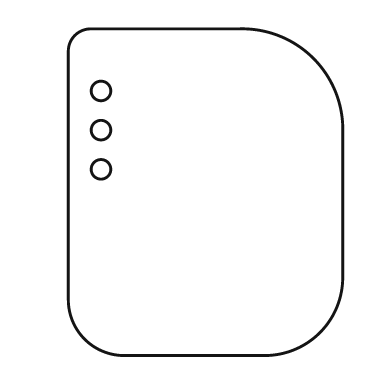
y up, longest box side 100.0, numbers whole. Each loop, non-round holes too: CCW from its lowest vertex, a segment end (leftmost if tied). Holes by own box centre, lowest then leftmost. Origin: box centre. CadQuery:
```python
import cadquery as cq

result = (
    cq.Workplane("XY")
    .moveTo(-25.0, -50.0)
    .lineTo(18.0, -50.0)
    .threePointArc((35.0, -43.0), (42.0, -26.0))
    .lineTo(42.0, 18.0)
    .threePointArc((33.0, 41.0), (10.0, 50.0))
    .lineTo(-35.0, 50.0)
    .threePointArc((-40.0, 48.0), (-42.0, 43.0))
    .lineTo(-42.0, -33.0)
    .threePointArc((-37.0, -45.0), (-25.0, -50.0))
    .close()
    .moveTo(-32.0, 7.0)
    .circle(3.0)
    .moveTo(-32.0, 19.0)
    .circle(3.0)
    .moveTo(-32.0, 31.0)
    .circle(3.0)
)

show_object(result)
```